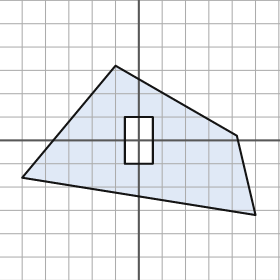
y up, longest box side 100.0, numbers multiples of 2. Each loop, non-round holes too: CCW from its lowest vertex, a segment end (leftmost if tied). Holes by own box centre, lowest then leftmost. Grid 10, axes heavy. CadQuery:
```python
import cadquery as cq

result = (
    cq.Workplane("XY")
    .moveTo(50.0, -32.0)
    .lineTo(42.0, 2.0)
    .lineTo(-10.0, 32.0)
    .lineTo(-50.0, -16.0)
    .close()
    .moveTo(-6.0, -10.0)
    .lineTo(6.0, -10.0)
    .lineTo(6.0, 10.0)
    .lineTo(-6.0, 10.0)
    .close()
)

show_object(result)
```